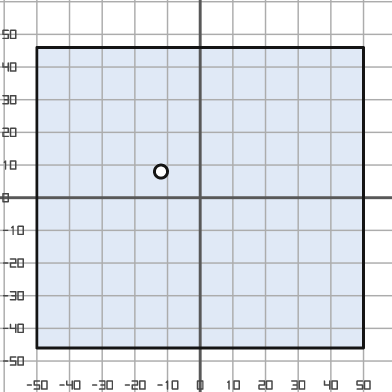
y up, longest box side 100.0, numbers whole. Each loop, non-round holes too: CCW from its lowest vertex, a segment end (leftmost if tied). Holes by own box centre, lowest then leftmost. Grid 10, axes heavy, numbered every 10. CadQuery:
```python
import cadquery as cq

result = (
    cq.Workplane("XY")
    .moveTo(-50.0, -46.0)
    .lineTo(50.0, -46.0)
    .lineTo(50.0, 46.0)
    .lineTo(-50.0, 46.0)
    .close()
    .moveTo(-12.0, 8.0)
    .circle(2.0)
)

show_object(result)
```